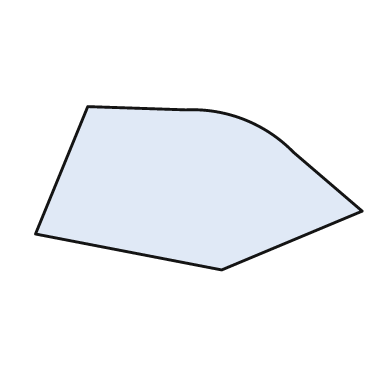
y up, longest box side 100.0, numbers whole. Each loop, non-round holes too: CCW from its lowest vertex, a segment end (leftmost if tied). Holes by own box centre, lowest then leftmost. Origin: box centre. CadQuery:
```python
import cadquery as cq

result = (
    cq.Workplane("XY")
    .moveTo(7.0, -25.0)
    .lineTo(50.0, -7.0)
    .lineTo(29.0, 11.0)
    .threePointArc((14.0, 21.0), (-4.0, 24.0))
    .lineTo(-34.0, 25.0)
    .lineTo(-50.0, -14.0)
    .close()
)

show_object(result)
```